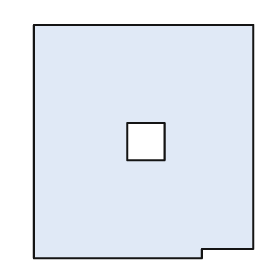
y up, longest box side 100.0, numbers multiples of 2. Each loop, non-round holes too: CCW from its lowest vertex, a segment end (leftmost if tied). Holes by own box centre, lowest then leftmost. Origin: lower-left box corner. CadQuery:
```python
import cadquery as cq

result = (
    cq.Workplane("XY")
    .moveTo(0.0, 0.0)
    .lineTo(72.0, 0.0)
    .lineTo(72.0, 4.0)
    .lineTo(94.0, 4.0)
    .lineTo(94.0, 100.0)
    .lineTo(0.0, 100.0)
    .close()
    .moveTo(40.0, 42.0)
    .lineTo(56.0, 42.0)
    .lineTo(56.0, 58.0)
    .lineTo(40.0, 58.0)
    .close()
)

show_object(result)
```